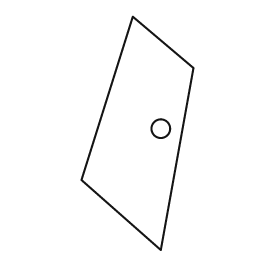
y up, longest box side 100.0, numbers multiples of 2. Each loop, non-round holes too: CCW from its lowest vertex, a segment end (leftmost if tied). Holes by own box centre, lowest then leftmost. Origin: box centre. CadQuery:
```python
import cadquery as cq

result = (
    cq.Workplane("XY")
    .moveTo(10.0, -50.0)
    .lineTo(24.0, 28.0)
    .lineTo(-2.0, 50.0)
    .lineTo(-24.0, -20.0)
    .close()
    .moveTo(10.0, 2.0)
    .circle(4.0)
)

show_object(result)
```